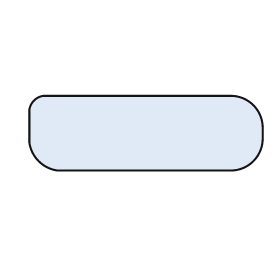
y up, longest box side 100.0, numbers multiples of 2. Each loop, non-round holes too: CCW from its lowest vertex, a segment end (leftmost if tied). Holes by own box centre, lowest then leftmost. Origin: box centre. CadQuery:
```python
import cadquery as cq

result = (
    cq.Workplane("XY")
    .moveTo(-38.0, -16.0)
    .lineTo(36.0, -16.0)
    .threePointArc((46.0, -12.0), (50.0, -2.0))
    .lineTo(50.0, 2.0)
    .threePointArc((46.0, 12.0), (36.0, 16.0))
    .lineTo(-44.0, 16.0)
    .threePointArc((-48.0, 14.0), (-50.0, 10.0))
    .lineTo(-50.0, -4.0)
    .threePointArc((-46.0, -12.0), (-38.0, -16.0))
    .close()
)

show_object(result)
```